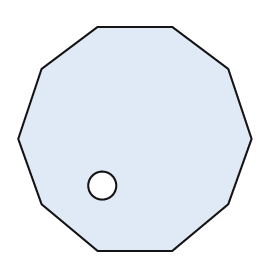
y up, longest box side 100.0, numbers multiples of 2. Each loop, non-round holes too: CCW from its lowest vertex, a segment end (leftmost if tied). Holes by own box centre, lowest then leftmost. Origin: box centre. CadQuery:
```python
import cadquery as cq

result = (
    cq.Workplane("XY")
    .moveTo(-16.0, -48.0)
    .lineTo(16.0, -48.0)
    .lineTo(40.0, -28.0)
    .lineTo(50.0, 0.0)
    .lineTo(40.0, 30.0)
    .lineTo(16.0, 48.0)
    .lineTo(-16.0, 48.0)
    .lineTo(-40.0, 30.0)
    .lineTo(-50.0, 0.0)
    .lineTo(-40.0, -28.0)
    .close()
    .moveTo(-14.0, -20.0)
    .circle(6.0)
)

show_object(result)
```